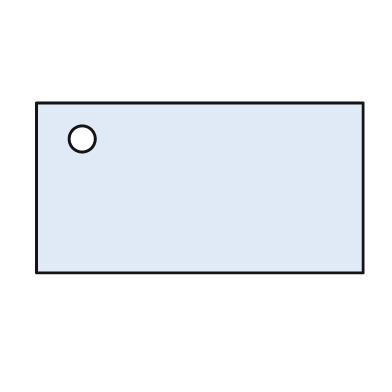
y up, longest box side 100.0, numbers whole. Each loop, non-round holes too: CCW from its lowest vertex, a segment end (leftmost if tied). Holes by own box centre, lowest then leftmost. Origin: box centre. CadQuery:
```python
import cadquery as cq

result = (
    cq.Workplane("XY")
    .moveTo(-50.0, -26.0)
    .lineTo(50.0, -26.0)
    .lineTo(50.0, 26.0)
    .lineTo(-50.0, 26.0)
    .close()
    .moveTo(-36.0, 15.0)
    .circle(4.0)
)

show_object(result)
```